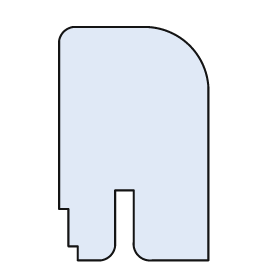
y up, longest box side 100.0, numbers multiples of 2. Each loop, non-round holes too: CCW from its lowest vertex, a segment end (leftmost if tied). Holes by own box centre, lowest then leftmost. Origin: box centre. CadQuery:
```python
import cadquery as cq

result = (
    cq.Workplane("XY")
    .moveTo(-24.0, -50.0)
    .lineTo(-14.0, -50.0)
    .threePointArc((-10.0, -48.0), (-8.0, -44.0))
    .lineTo(-8.0, -20.0)
    .lineTo(0.0, -20.0)
    .lineTo(0.0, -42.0)
    .threePointArc((2.0, -48.0), (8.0, -50.0))
    .lineTo(32.0, -50.0)
    .lineTo(32.0, 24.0)
    .threePointArc((24.0, 42.0), (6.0, 50.0))
    .lineTo(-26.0, 50.0)
    .threePointArc((-30.0, 48.0), (-32.0, 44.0))
    .lineTo(-32.0, -28.0)
    .lineTo(-28.0, -28.0)
    .lineTo(-28.0, -44.0)
    .lineTo(-24.0, -44.0)
    .close()
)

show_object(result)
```